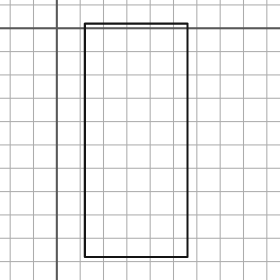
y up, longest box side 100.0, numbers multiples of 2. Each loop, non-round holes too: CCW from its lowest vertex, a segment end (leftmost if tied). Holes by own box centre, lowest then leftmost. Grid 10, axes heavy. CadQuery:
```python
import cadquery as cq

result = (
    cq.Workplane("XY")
    .moveTo(12.0, -98.0)
    .lineTo(56.0, -98.0)
    .lineTo(56.0, 2.0)
    .lineTo(12.0, 2.0)
    .close()
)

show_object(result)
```